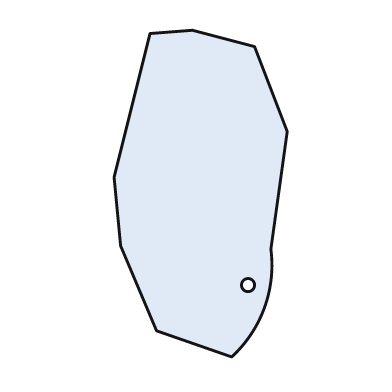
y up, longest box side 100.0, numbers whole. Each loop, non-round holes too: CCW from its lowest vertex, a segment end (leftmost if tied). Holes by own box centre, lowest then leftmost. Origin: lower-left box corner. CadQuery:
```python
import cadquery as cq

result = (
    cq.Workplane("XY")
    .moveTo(36.0, 0.0)
    .threePointArc((46.0, 15.0), (48.0, 33.0))
    .lineTo(53.0, 69.0)
    .lineTo(43.0, 95.0)
    .lineTo(24.0, 100.0)
    .lineTo(11.0, 99.0)
    .lineTo(0.0, 55.0)
    .lineTo(2.0, 34.0)
    .lineTo(13.0, 8.0)
    .close()
    .moveTo(41.0, 22.0)
    .circle(2.0)
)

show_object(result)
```